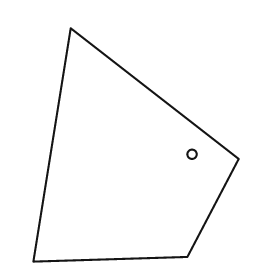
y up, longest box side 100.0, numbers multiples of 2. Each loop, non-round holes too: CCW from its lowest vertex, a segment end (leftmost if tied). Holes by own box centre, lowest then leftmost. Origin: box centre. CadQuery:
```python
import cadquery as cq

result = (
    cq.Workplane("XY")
    .moveTo(-44.0, -50.0)
    .lineTo(22.0, -48.0)
    .lineTo(44.0, -6.0)
    .lineTo(-28.0, 50.0)
    .close()
    .moveTo(24.0, -4.0)
    .circle(2.0)
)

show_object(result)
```